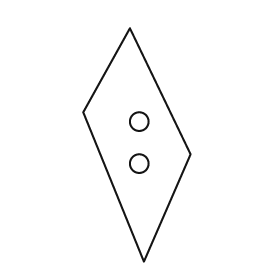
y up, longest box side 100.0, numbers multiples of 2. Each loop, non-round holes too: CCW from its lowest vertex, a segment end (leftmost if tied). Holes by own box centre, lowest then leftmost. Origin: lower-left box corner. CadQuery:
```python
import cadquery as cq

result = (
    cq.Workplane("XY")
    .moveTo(26.0, 0.0)
    .lineTo(46.0, 46.0)
    .lineTo(20.0, 100.0)
    .lineTo(0.0, 64.0)
    .close()
    .moveTo(24.0, 42.0)
    .circle(4.0)
    .moveTo(24.0, 60.0)
    .circle(4.0)
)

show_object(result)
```